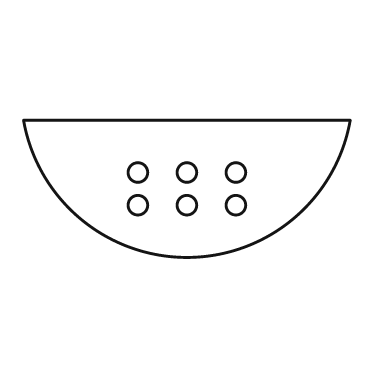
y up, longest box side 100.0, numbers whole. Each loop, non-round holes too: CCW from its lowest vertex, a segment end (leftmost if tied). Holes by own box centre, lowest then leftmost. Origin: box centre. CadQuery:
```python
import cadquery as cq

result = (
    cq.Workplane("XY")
    .moveTo(-50.0, 21.0)
    .threePointArc((0.0, -21.0), (50.0, 21.0))
    .close()
    .moveTo(-15.0, -5.0)
    .circle(3.0)
    .moveTo(0.0, -5.0)
    .circle(3.0)
    .moveTo(15.0, -5.0)
    .circle(3.0)
    .moveTo(-15.0, 5.0)
    .circle(3.0)
    .moveTo(0.0, 5.0)
    .circle(3.0)
    .moveTo(15.0, 5.0)
    .circle(3.0)
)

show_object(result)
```